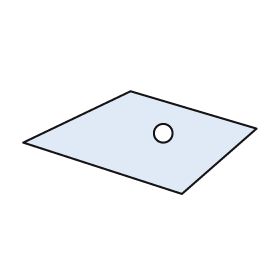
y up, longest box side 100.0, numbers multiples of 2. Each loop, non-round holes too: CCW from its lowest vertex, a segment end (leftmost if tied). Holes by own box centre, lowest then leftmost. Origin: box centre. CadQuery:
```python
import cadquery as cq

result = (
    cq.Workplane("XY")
    .moveTo(18.0, -22.0)
    .lineTo(50.0, 6.0)
    .lineTo(-4.0, 22.0)
    .lineTo(-50.0, 0.0)
    .close()
    .moveTo(10.0, 4.0)
    .circle(4.0)
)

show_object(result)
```